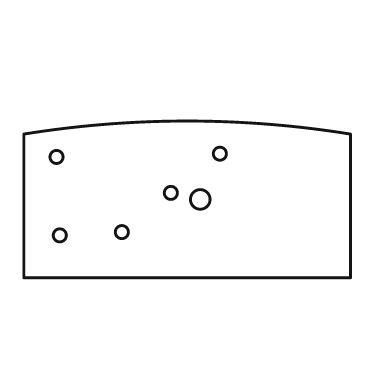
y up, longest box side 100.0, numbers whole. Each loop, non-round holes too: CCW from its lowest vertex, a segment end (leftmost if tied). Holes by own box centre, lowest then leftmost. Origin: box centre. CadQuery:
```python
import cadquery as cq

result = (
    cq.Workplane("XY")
    .moveTo(-50.0, -24.0)
    .lineTo(50.0, -24.0)
    .lineTo(50.0, 20.0)
    .threePointArc((0.0, 24.0), (-50.0, 20.0))
    .close()
    .moveTo(-39.0, -11.0)
    .circle(2.0)
    .moveTo(-20.0, -10.0)
    .circle(2.0)
    .moveTo(4.0, 0.0)
    .circle(3.0)
    .moveTo(-5.0, 2.0)
    .circle(2.0)
    .moveTo(-40.0, 13.0)
    .circle(2.0)
    .moveTo(10.0, 14.0)
    .circle(2.0)
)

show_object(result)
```